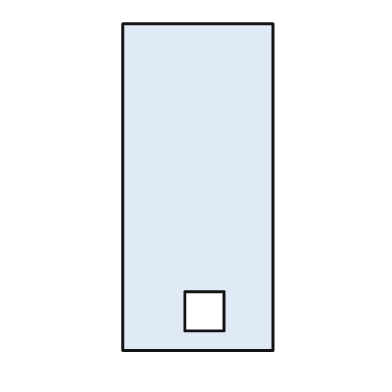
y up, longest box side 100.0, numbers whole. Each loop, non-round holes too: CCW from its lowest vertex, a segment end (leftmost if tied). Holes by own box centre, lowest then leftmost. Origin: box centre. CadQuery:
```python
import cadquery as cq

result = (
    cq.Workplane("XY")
    .moveTo(-23.0, -50.0)
    .lineTo(23.0, -50.0)
    .lineTo(23.0, 50.0)
    .lineTo(-23.0, 50.0)
    .close()
    .moveTo(-4.0, -44.0)
    .lineTo(8.0, -44.0)
    .lineTo(8.0, -32.0)
    .lineTo(-4.0, -32.0)
    .close()
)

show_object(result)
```